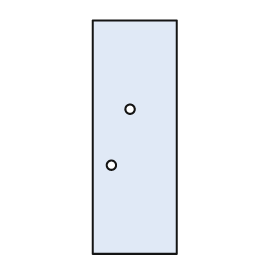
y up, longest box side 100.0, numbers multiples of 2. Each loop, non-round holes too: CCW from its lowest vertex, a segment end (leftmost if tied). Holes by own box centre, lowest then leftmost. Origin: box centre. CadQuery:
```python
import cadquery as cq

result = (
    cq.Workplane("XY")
    .moveTo(-18.0, -50.0)
    .lineTo(18.0, -50.0)
    .lineTo(18.0, 50.0)
    .lineTo(-18.0, 50.0)
    .close()
    .moveTo(-10.0, -12.0)
    .circle(2.0)
    .moveTo(-2.0, 12.0)
    .circle(2.0)
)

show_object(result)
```